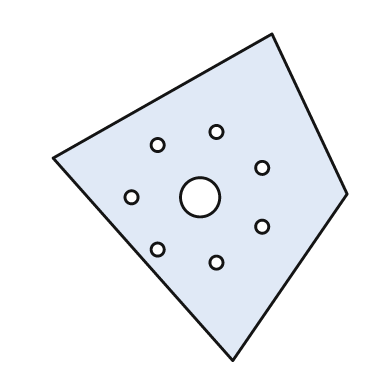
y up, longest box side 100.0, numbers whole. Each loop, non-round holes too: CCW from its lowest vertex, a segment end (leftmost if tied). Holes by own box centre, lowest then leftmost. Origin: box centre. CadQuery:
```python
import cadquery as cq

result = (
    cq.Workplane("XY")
    .moveTo(10.0, -50.0)
    .lineTo(45.0, 1.0)
    .lineTo(22.0, 50.0)
    .lineTo(-45.0, 12.0)
    .close()
    .moveTo(5.0, -20.0)
    .circle(2.0)
    .moveTo(-13.0, -16.0)
    .circle(2.0)
    .moveTo(19.0, -9.0)
    .circle(2.0)
    .moveTo(-21.0, 0.0)
    .circle(2.0)
    .moveTo(0.0, 0.0)
    .circle(6.0)
    .moveTo(19.0, 9.0)
    .circle(2.0)
    .moveTo(-13.0, 16.0)
    .circle(2.0)
    .moveTo(5.0, 20.0)
    .circle(2.0)
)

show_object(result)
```